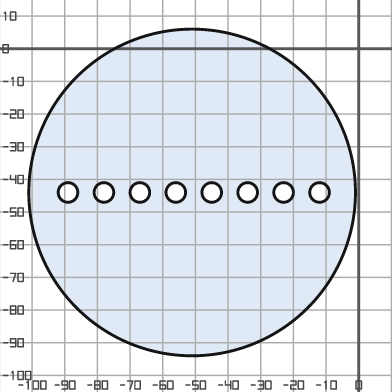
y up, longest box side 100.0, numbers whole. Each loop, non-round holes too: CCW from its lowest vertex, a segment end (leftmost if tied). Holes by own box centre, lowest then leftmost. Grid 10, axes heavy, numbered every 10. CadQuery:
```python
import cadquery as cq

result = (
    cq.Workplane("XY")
    .moveTo(-51.0, -44.0)
    .circle(50.0)
    .moveTo(-89.0, -44.0)
    .circle(3.0)
    .moveTo(-78.0, -44.0)
    .circle(3.0)
    .moveTo(-67.0, -44.0)
    .circle(3.0)
    .moveTo(-56.0, -44.0)
    .circle(3.0)
    .moveTo(-45.0, -44.0)
    .circle(3.0)
    .moveTo(-34.0, -44.0)
    .circle(3.0)
    .moveTo(-23.0, -44.0)
    .circle(3.0)
    .moveTo(-12.0, -44.0)
    .circle(3.0)
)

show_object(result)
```